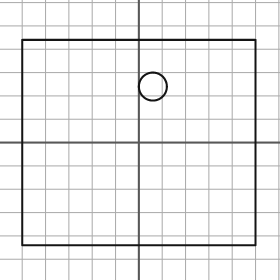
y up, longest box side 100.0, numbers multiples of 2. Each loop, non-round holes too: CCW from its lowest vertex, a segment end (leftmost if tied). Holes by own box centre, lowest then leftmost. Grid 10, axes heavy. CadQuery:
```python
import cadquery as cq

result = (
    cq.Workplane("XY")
    .moveTo(-50.0, -44.0)
    .lineTo(50.0, -44.0)
    .lineTo(50.0, 44.0)
    .lineTo(-50.0, 44.0)
    .close()
    .moveTo(6.0, 24.0)
    .circle(6.0)
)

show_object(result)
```